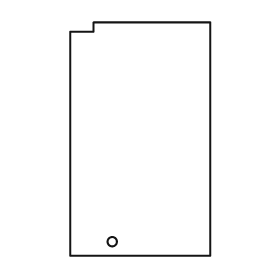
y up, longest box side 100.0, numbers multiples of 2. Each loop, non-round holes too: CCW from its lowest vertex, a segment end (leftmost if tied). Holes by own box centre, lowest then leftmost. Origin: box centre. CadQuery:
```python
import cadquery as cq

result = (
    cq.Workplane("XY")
    .moveTo(-30.0, -50.0)
    .lineTo(30.0, -50.0)
    .lineTo(30.0, 50.0)
    .lineTo(-20.0, 50.0)
    .lineTo(-20.0, 46.0)
    .lineTo(-30.0, 46.0)
    .close()
    .moveTo(-12.0, -44.0)
    .circle(2.0)
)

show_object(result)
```